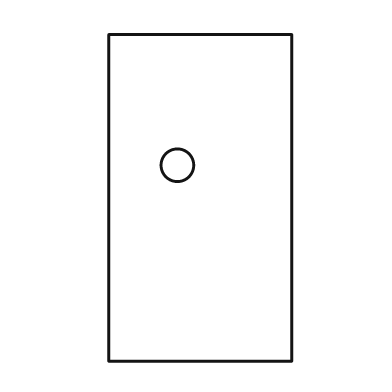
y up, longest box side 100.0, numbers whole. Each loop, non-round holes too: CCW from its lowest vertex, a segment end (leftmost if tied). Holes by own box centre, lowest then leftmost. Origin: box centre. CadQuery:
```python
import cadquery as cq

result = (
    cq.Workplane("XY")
    .moveTo(-28.0, -50.0)
    .lineTo(28.0, -50.0)
    .lineTo(28.0, 50.0)
    .lineTo(-28.0, 50.0)
    .close()
    .moveTo(-7.0, 10.0)
    .circle(5.0)
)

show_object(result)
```